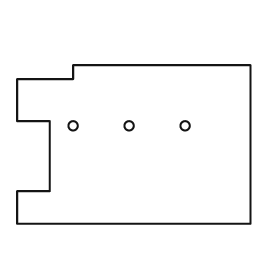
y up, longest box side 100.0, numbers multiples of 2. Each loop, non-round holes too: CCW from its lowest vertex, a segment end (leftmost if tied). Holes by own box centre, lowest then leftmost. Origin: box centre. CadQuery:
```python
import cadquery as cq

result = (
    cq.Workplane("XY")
    .moveTo(-50.0, -34.0)
    .lineTo(50.0, -34.0)
    .lineTo(50.0, 34.0)
    .lineTo(-26.0, 34.0)
    .lineTo(-26.0, 28.0)
    .lineTo(-50.0, 28.0)
    .lineTo(-50.0, 10.0)
    .lineTo(-36.0, 10.0)
    .lineTo(-36.0, -20.0)
    .lineTo(-50.0, -20.0)
    .close()
    .moveTo(-26.0, 8.0)
    .circle(2.0)
    .moveTo(-2.0, 8.0)
    .circle(2.0)
    .moveTo(22.0, 8.0)
    .circle(2.0)
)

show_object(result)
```